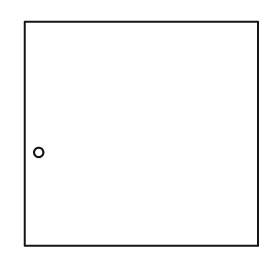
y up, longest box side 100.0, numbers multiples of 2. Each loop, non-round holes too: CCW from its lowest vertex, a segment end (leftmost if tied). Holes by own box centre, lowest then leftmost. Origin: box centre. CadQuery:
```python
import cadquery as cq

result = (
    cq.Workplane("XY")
    .moveTo(-50.0, -48.0)
    .lineTo(50.0, -48.0)
    .lineTo(50.0, 48.0)
    .lineTo(-50.0, 48.0)
    .close()
    .moveTo(-44.0, -8.0)
    .circle(2.0)
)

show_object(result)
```